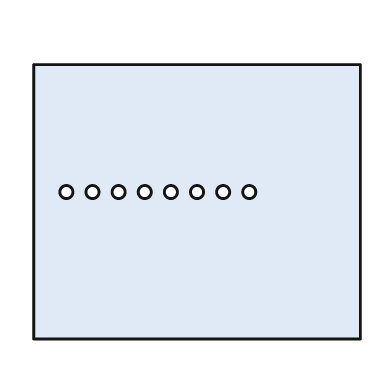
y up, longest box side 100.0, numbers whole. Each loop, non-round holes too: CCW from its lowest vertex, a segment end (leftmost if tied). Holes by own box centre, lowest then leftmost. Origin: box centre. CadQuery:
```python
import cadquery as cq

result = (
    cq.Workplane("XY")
    .moveTo(-50.0, -42.0)
    .lineTo(50.0, -42.0)
    .lineTo(50.0, 42.0)
    .lineTo(-50.0, 42.0)
    .close()
    .moveTo(-40.0, 3.0)
    .circle(2.0)
    .moveTo(-32.0, 3.0)
    .circle(2.0)
    .moveTo(-24.0, 3.0)
    .circle(2.0)
    .moveTo(-16.0, 3.0)
    .circle(2.0)
    .moveTo(-8.0, 3.0)
    .circle(2.0)
    .moveTo(0.0, 3.0)
    .circle(2.0)
    .moveTo(8.0, 3.0)
    .circle(2.0)
    .moveTo(16.0, 3.0)
    .circle(2.0)
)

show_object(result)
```